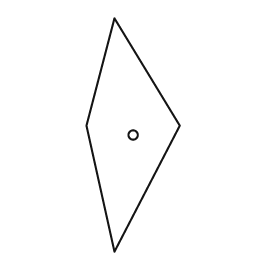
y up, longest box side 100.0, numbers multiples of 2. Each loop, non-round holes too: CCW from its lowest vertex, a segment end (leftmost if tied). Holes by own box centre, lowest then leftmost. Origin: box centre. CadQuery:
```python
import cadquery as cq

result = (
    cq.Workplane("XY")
    .moveTo(-8.0, -50.0)
    .lineTo(20.0, 4.0)
    .lineTo(-8.0, 50.0)
    .lineTo(-20.0, 4.0)
    .close()
    .moveTo(0.0, 0.0)
    .circle(2.0)
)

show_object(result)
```